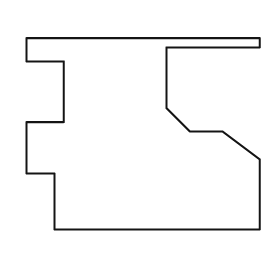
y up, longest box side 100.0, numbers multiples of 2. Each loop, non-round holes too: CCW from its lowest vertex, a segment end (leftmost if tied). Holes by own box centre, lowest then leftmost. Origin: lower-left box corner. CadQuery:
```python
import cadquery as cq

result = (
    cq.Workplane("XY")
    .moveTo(12.0, 0.0)
    .lineTo(100.0, 0.0)
    .lineTo(100.0, 30.0)
    .lineTo(84.0, 42.0)
    .lineTo(70.0, 42.0)
    .lineTo(60.0, 52.0)
    .lineTo(60.0, 78.0)
    .lineTo(100.0, 78.0)
    .lineTo(100.0, 82.0)
    .lineTo(0.0, 82.0)
    .lineTo(0.0, 72.0)
    .lineTo(16.0, 72.0)
    .lineTo(16.0, 46.0)
    .lineTo(0.0, 46.0)
    .lineTo(0.0, 24.0)
    .lineTo(12.0, 24.0)
    .close()
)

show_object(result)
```